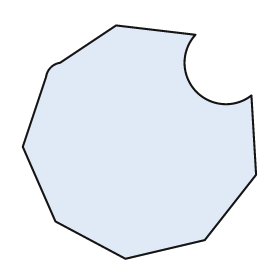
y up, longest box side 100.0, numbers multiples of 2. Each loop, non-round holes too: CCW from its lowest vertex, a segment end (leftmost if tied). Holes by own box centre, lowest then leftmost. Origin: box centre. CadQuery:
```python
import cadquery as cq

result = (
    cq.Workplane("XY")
    .moveTo(-6.0, -50.0)
    .lineTo(28.0, -42.0)
    .lineTo(50.0, -14.0)
    .lineTo(48.0, 20.0)
    .threePointArc((24.0, 22.0), (24.0, 46.0))
    .lineTo(-10.0, 50.0)
    .lineTo(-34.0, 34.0)
    .threePointArc((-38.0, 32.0), (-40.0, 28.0))
    .lineTo(-50.0, -2.0)
    .lineTo(-36.0, -34.0)
    .close()
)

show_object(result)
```